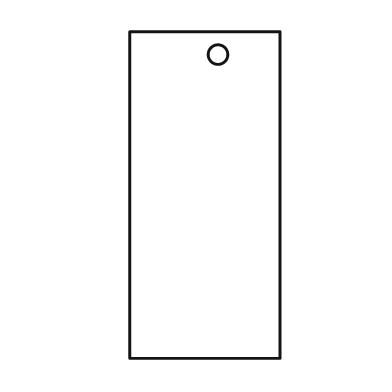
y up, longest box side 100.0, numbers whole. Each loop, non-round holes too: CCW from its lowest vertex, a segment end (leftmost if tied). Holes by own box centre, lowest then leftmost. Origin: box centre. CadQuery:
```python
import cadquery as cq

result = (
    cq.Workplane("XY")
    .moveTo(-23.0, -50.0)
    .lineTo(23.0, -50.0)
    .lineTo(23.0, 50.0)
    .lineTo(-23.0, 50.0)
    .close()
    .moveTo(4.0, 43.0)
    .circle(3.0)
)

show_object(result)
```